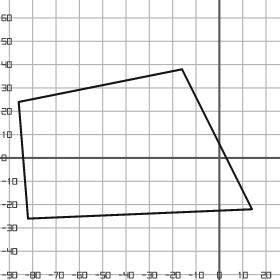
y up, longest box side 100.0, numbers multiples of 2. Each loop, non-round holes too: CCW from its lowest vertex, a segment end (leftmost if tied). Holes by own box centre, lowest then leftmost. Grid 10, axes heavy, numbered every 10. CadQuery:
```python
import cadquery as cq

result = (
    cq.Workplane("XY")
    .moveTo(-82.0, -26.0)
    .lineTo(14.0, -22.0)
    .lineTo(-16.0, 38.0)
    .lineTo(-86.0, 24.0)
    .close()
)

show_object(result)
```